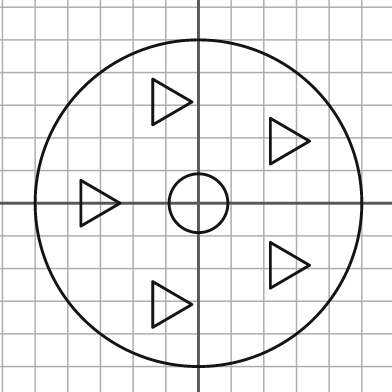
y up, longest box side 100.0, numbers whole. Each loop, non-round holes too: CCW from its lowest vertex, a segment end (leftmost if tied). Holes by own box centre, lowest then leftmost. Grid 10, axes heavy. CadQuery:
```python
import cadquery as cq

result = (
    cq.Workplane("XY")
    .moveTo(0.0, 0.0)
    .circle(50.0)
    .moveTo(-14.0, -38.0)
    .lineTo(-2.0, -31.0)
    .lineTo(-14.0, -24.0)
    .close()
    .moveTo(22.0, -26.0)
    .lineTo(34.0, -19.0)
    .lineTo(22.0, -12.0)
    .close()
    .moveTo(-36.0, -7.0)
    .lineTo(-24.0, 0.0)
    .lineTo(-36.0, 7.0)
    .close()
    .moveTo(0.0, 0.0)
    .circle(9.0)
    .moveTo(22.0, 12.0)
    .lineTo(34.0, 19.0)
    .lineTo(22.0, 26.0)
    .close()
    .moveTo(-14.0, 24.0)
    .lineTo(-2.0, 31.0)
    .lineTo(-14.0, 38.0)
    .close()
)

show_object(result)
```